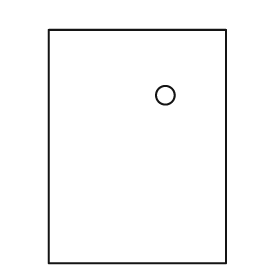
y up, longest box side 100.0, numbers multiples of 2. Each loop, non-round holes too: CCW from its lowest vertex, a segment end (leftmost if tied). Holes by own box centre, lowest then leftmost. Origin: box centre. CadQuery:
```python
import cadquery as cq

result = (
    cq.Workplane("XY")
    .moveTo(-38.0, -50.0)
    .lineTo(38.0, -50.0)
    .lineTo(38.0, 50.0)
    .lineTo(-38.0, 50.0)
    .close()
    .moveTo(12.0, 22.0)
    .circle(4.0)
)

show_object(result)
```